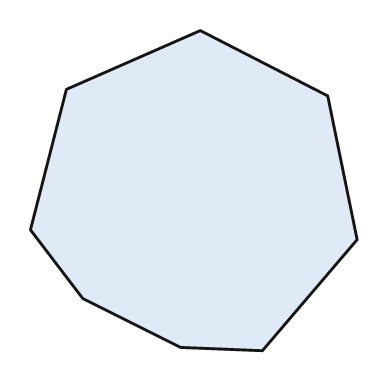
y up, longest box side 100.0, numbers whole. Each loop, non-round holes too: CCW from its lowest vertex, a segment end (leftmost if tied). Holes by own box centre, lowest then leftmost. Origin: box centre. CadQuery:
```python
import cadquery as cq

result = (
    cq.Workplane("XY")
    .moveTo(21.0, -49.0)
    .lineTo(50.0, -15.0)
    .lineTo(41.0, 29.0)
    .lineTo(2.0, 49.0)
    .lineTo(-39.0, 31.0)
    .lineTo(-50.0, -12.0)
    .lineTo(-34.0, -33.0)
    .lineTo(-4.0, -48.0)
    .close()
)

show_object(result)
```